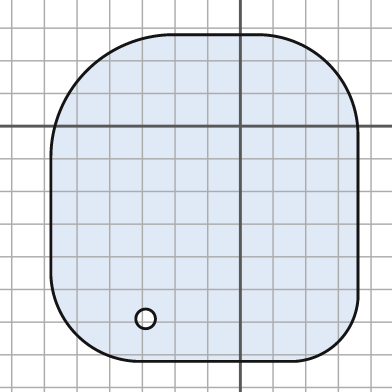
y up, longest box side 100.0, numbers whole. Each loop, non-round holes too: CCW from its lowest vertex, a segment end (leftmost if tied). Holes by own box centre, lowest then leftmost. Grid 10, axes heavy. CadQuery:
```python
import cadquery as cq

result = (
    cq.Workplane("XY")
    .moveTo(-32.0, -72.0)
    .lineTo(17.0, -72.0)
    .threePointArc((30.0, -66.0), (36.0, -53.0))
    .lineTo(36.0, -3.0)
    .threePointArc((27.0, 19.0), (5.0, 28.0))
    .lineTo(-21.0, 28.0)
    .threePointArc((-47.0, 17.0), (-58.0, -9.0))
    .lineTo(-58.0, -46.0)
    .threePointArc((-50.0, -64.0), (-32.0, -72.0))
    .close()
    .moveTo(-29.0, -59.0)
    .circle(3.0)
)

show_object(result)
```